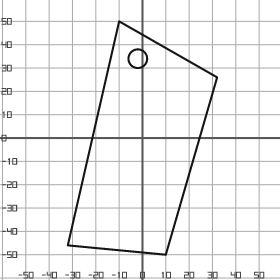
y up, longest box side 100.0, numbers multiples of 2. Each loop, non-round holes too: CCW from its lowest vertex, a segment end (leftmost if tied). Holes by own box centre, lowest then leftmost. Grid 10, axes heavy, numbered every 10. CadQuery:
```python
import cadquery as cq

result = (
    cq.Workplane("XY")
    .moveTo(10.0, -50.0)
    .lineTo(32.0, 26.0)
    .lineTo(-10.0, 50.0)
    .lineTo(-32.0, -46.0)
    .close()
    .moveTo(-2.0, 34.0)
    .circle(4.0)
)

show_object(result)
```